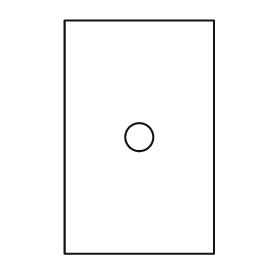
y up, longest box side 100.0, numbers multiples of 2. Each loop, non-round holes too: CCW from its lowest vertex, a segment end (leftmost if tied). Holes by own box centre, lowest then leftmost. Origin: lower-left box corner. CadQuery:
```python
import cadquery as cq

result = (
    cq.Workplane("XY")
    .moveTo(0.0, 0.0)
    .lineTo(64.0, 0.0)
    .lineTo(64.0, 100.0)
    .lineTo(0.0, 100.0)
    .close()
    .moveTo(32.0, 50.0)
    .circle(6.0)
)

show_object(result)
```